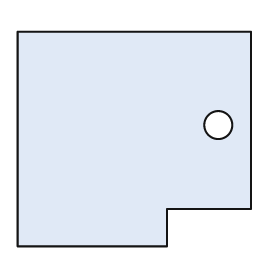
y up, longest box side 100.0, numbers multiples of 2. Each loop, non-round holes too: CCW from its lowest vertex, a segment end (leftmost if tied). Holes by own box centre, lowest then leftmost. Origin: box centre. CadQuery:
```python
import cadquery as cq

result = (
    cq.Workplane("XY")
    .moveTo(-50.0, -46.0)
    .lineTo(14.0, -46.0)
    .lineTo(14.0, -30.0)
    .lineTo(50.0, -30.0)
    .lineTo(50.0, 46.0)
    .lineTo(-50.0, 46.0)
    .close()
    .moveTo(36.0, 6.0)
    .circle(6.0)
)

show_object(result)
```